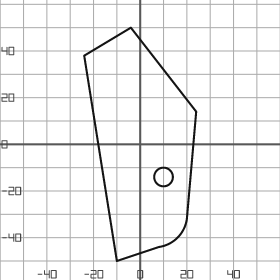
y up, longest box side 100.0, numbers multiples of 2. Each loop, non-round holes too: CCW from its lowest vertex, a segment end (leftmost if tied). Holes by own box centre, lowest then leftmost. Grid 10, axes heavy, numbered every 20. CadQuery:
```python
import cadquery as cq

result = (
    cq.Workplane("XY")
    .moveTo(-10.0, -50.0)
    .lineTo(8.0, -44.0)
    .threePointArc((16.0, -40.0), (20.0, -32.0))
    .lineTo(24.0, 14.0)
    .lineTo(-4.0, 50.0)
    .lineTo(-24.0, 38.0)
    .close()
    .moveTo(10.0, -14.0)
    .circle(4.0)
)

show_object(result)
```